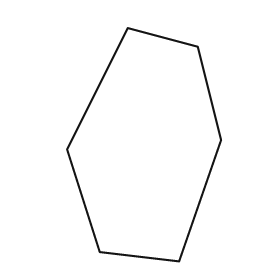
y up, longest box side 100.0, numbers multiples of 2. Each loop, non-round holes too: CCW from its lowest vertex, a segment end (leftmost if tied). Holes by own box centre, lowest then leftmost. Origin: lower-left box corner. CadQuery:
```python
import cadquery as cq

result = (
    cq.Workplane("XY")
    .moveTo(48.0, 0.0)
    .lineTo(66.0, 52.0)
    .lineTo(56.0, 92.0)
    .lineTo(26.0, 100.0)
    .lineTo(0.0, 48.0)
    .lineTo(14.0, 4.0)
    .close()
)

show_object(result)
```